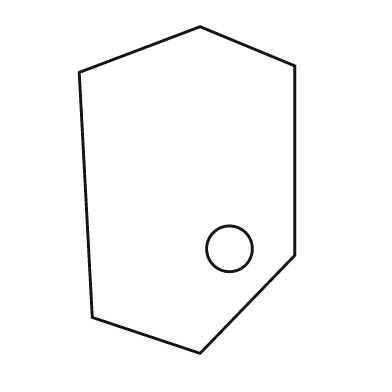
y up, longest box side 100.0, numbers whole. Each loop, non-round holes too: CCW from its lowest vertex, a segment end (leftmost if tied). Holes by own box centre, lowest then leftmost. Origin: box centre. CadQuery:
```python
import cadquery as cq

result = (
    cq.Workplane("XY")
    .moveTo(4.0, -50.0)
    .lineTo(33.0, -20.0)
    .lineTo(33.0, 38.0)
    .lineTo(4.0, 50.0)
    .lineTo(-33.0, 36.0)
    .lineTo(-29.0, -39.0)
    .close()
    .moveTo(13.0, -18.0)
    .circle(7.0)
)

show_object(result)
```